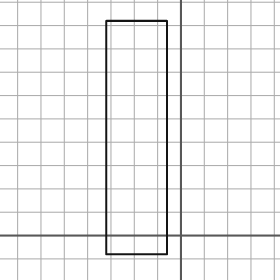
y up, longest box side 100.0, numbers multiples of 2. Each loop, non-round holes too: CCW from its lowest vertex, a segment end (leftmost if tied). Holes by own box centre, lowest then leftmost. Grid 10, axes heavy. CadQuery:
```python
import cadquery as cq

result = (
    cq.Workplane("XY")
    .moveTo(-32.0, -8.0)
    .lineTo(-6.0, -8.0)
    .lineTo(-6.0, 92.0)
    .lineTo(-32.0, 92.0)
    .close()
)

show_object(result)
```